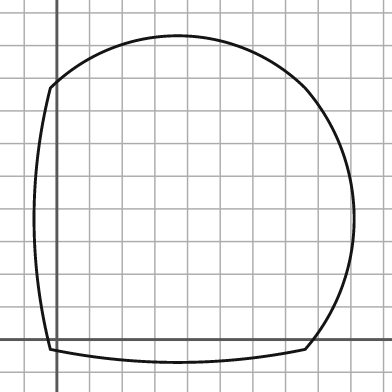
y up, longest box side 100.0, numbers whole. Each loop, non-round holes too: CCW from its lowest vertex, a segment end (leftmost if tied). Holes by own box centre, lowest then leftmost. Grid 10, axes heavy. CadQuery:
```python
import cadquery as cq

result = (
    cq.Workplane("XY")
    .moveTo(-2.0, -3.0)
    .threePointArc((37.0, -7.0), (76.0, -3.0))
    .threePointArc((91.0, 37.0), (76.0, 77.0))
    .threePointArc((37.0, 93.0), (-2.0, 77.0))
    .threePointArc((-7.0, 37.0), (-2.0, -3.0))
    .close()
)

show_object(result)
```